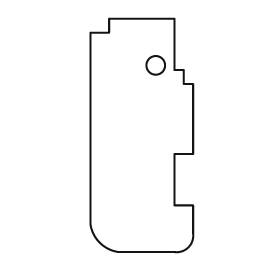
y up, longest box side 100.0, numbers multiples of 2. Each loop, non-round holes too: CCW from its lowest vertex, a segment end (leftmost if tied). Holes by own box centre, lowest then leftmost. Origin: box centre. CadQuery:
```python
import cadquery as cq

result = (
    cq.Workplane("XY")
    .moveTo(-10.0, -50.0)
    .lineTo(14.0, -50.0)
    .threePointArc((20.0, -48.0), (22.0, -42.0))
    .lineTo(22.0, -30.0)
    .lineTo(14.0, -30.0)
    .lineTo(14.0, -8.0)
    .lineTo(22.0, -8.0)
    .lineTo(22.0, 22.0)
    .lineTo(18.0, 22.0)
    .lineTo(18.0, 28.0)
    .lineTo(14.0, 28.0)
    .lineTo(14.0, 50.0)
    .lineTo(-14.0, 50.0)
    .lineTo(-14.0, 44.0)
    .lineTo(-22.0, 44.0)
    .lineTo(-22.0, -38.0)
    .threePointArc((-18.0, -46.0), (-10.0, -50.0))
    .close()
    .moveTo(6.0, 30.0)
    .circle(4.0)
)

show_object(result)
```